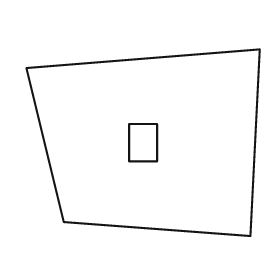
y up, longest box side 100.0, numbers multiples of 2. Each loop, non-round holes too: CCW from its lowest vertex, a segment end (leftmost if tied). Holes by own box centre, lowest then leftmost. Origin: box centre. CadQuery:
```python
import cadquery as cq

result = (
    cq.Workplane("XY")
    .moveTo(46.0, -40.0)
    .lineTo(50.0, 40.0)
    .lineTo(-50.0, 32.0)
    .lineTo(-34.0, -34.0)
    .close()
    .moveTo(-6.0, -8.0)
    .lineTo(6.0, -8.0)
    .lineTo(6.0, 8.0)
    .lineTo(-6.0, 8.0)
    .close()
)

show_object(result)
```